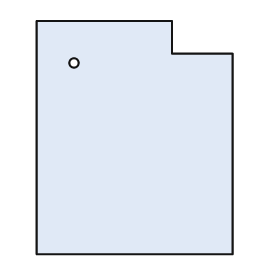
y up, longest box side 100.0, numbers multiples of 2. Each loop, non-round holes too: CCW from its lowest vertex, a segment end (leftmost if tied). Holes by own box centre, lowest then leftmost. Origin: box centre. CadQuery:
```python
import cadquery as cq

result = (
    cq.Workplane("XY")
    .moveTo(-42.0, -50.0)
    .lineTo(42.0, -50.0)
    .lineTo(42.0, 36.0)
    .lineTo(16.0, 36.0)
    .lineTo(16.0, 50.0)
    .lineTo(-42.0, 50.0)
    .close()
    .moveTo(-26.0, 32.0)
    .circle(2.0)
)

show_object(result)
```